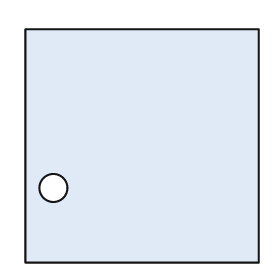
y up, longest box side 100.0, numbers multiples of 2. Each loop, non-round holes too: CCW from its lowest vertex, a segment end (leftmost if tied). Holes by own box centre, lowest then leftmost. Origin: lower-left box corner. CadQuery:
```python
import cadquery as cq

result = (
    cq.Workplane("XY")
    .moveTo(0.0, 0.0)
    .lineTo(100.0, 0.0)
    .lineTo(100.0, 100.0)
    .lineTo(0.0, 100.0)
    .close()
    .moveTo(12.0, 32.0)
    .circle(6.0)
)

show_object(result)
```